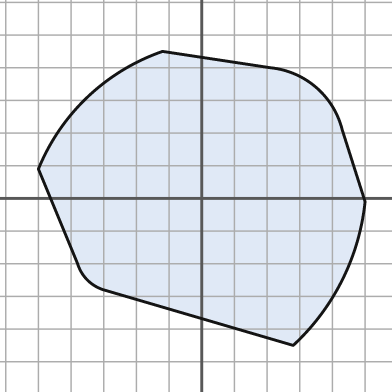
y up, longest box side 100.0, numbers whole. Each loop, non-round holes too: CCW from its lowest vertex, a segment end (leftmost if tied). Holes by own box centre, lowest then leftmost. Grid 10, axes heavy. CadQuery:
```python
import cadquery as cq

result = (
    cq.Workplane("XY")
    .moveTo(28.0, -45.0)
    .threePointArc((43.0, -25.0), (50.0, -1.0))
    .lineTo(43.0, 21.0)
    .threePointArc((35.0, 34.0), (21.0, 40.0))
    .lineTo(-12.0, 45.0)
    .threePointArc((-35.0, 31.0), (-50.0, 9.0))
    .lineTo(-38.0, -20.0)
    .threePointArc((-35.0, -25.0), (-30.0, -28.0))
    .close()
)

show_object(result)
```